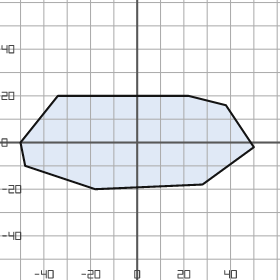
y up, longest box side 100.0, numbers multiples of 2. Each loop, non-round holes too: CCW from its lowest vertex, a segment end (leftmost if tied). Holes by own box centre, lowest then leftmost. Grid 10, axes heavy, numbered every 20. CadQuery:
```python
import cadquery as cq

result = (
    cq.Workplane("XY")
    .moveTo(-18.0, -20.0)
    .lineTo(28.0, -18.0)
    .lineTo(50.0, -2.0)
    .lineTo(38.0, 16.0)
    .lineTo(22.0, 20.0)
    .lineTo(-34.0, 20.0)
    .lineTo(-50.0, 0.0)
    .lineTo(-48.0, -10.0)
    .close()
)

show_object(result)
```